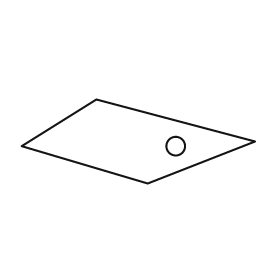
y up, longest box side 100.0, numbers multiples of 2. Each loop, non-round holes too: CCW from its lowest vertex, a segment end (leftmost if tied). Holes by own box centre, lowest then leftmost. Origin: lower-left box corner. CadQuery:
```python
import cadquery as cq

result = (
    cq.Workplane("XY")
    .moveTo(54.0, 0.0)
    .lineTo(100.0, 18.0)
    .lineTo(32.0, 36.0)
    .lineTo(0.0, 16.0)
    .close()
    .moveTo(66.0, 16.0)
    .circle(4.0)
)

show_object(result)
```